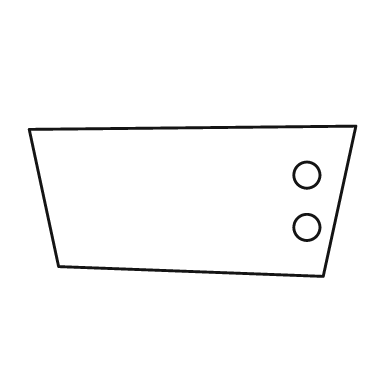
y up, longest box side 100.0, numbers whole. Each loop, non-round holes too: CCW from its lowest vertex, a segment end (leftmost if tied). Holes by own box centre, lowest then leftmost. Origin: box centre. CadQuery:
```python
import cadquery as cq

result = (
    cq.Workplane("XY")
    .moveTo(40.0, -23.0)
    .lineTo(50.0, 23.0)
    .lineTo(-50.0, 22.0)
    .lineTo(-41.0, -20.0)
    .close()
    .moveTo(35.0, -8.0)
    .circle(4.0)
    .moveTo(35.0, 8.0)
    .circle(4.0)
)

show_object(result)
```